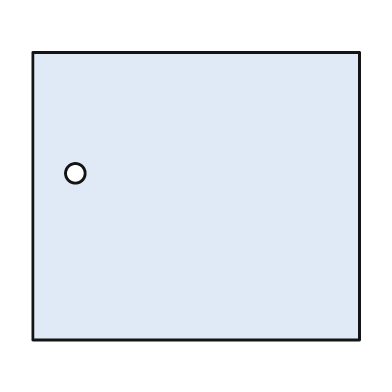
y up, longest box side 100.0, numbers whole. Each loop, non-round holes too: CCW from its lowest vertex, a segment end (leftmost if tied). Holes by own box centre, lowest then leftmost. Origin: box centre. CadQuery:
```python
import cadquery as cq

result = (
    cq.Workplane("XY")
    .moveTo(-50.0, -44.0)
    .lineTo(50.0, -44.0)
    .lineTo(50.0, 44.0)
    .lineTo(-50.0, 44.0)
    .close()
    .moveTo(-37.0, 7.0)
    .circle(3.0)
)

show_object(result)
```